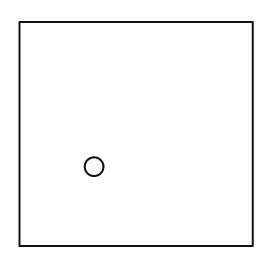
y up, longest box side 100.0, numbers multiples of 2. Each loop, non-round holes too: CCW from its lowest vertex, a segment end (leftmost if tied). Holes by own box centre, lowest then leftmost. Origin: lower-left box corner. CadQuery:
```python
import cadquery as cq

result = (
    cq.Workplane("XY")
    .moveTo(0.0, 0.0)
    .lineTo(100.0, 0.0)
    .lineTo(100.0, 96.0)
    .lineTo(0.0, 96.0)
    .close()
    .moveTo(32.0, 34.0)
    .circle(4.0)
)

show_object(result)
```